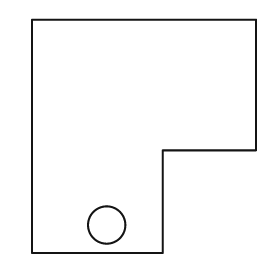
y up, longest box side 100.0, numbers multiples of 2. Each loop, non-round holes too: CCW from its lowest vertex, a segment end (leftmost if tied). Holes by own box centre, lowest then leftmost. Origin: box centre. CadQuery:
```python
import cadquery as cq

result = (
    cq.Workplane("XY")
    .moveTo(-48.0, -50.0)
    .lineTo(8.0, -50.0)
    .lineTo(8.0, -6.0)
    .lineTo(48.0, -6.0)
    .lineTo(48.0, 50.0)
    .lineTo(-48.0, 50.0)
    .close()
    .moveTo(-16.0, -38.0)
    .circle(8.0)
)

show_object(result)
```